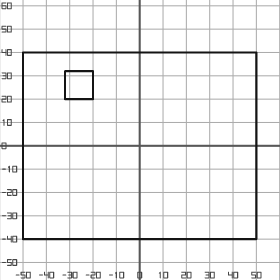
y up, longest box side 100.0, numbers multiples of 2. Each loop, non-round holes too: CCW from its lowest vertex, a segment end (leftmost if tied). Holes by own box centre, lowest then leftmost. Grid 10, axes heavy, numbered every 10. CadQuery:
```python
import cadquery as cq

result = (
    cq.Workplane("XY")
    .moveTo(-50.0, -40.0)
    .lineTo(50.0, -40.0)
    .lineTo(50.0, 40.0)
    .lineTo(-50.0, 40.0)
    .close()
    .moveTo(-32.0, 20.0)
    .lineTo(-20.0, 20.0)
    .lineTo(-20.0, 32.0)
    .lineTo(-32.0, 32.0)
    .close()
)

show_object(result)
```